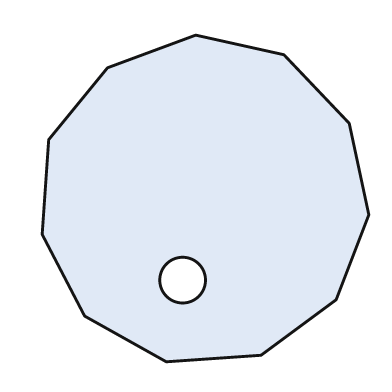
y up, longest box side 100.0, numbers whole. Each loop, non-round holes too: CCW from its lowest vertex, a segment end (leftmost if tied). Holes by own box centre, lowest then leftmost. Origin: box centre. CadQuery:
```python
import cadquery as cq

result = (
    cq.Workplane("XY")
    .moveTo(-12.0, -50.0)
    .lineTo(17.0, -48.0)
    .lineTo(40.0, -31.0)
    .lineTo(50.0, -5.0)
    .lineTo(44.0, 23.0)
    .lineTo(24.0, 44.0)
    .lineTo(-3.0, 50.0)
    .lineTo(-30.0, 40.0)
    .lineTo(-48.0, 18.0)
    .lineTo(-50.0, -11.0)
    .lineTo(-37.0, -36.0)
    .close()
    .moveTo(-7.0, -25.0)
    .circle(7.0)
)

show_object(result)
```